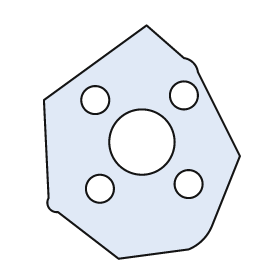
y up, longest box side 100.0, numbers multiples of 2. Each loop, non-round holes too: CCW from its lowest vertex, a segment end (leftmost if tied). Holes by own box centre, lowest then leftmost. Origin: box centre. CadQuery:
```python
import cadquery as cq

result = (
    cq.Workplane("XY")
    .moveTo(-10.0, -50.0)
    .lineTo(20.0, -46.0)
    .threePointArc((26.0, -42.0), (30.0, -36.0))
    .lineTo(42.0, -6.0)
    .lineTo(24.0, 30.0)
    .threePointArc((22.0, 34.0), (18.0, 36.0))
    .lineTo(2.0, 50.0)
    .lineTo(-42.0, 18.0)
    .lineTo(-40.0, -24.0)
    .threePointArc((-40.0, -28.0), (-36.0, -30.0))
    .close()
    .moveTo(-18.0, -20.0)
    .circle(6.0)
    .moveTo(20.0, -18.0)
    .circle(6.0)
    .moveTo(0.0, 0.0)
    .circle(14.0)
    .moveTo(-20.0, 18.0)
    .circle(6.0)
    .moveTo(18.0, 20.0)
    .circle(6.0)
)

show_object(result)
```